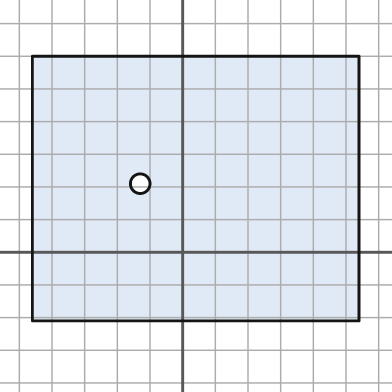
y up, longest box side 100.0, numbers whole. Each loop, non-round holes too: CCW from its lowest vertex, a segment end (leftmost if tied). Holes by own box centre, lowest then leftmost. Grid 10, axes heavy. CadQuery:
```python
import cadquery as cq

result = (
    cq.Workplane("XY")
    .moveTo(-46.0, -21.0)
    .lineTo(54.0, -21.0)
    .lineTo(54.0, 60.0)
    .lineTo(-46.0, 60.0)
    .close()
    .moveTo(-13.0, 21.0)
    .circle(3.0)
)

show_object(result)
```